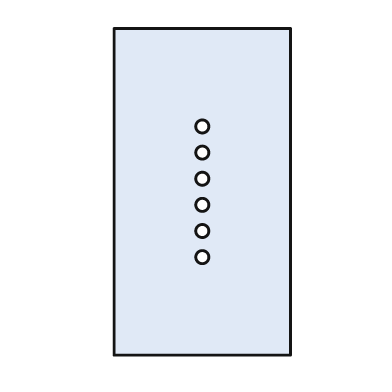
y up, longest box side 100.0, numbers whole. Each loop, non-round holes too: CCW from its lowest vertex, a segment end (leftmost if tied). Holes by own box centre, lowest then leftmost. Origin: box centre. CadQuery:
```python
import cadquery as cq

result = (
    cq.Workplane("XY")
    .moveTo(-27.0, -50.0)
    .lineTo(27.0, -50.0)
    .lineTo(27.0, 50.0)
    .lineTo(-27.0, 50.0)
    .close()
    .moveTo(0.0, -20.0)
    .circle(2.0)
    .moveTo(0.0, -12.0)
    .circle(2.0)
    .moveTo(0.0, -4.0)
    .circle(2.0)
    .moveTo(0.0, 4.0)
    .circle(2.0)
    .moveTo(0.0, 12.0)
    .circle(2.0)
    .moveTo(0.0, 20.0)
    .circle(2.0)
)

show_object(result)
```